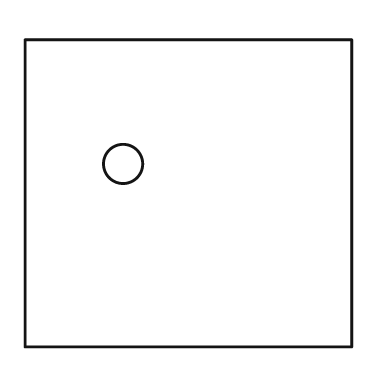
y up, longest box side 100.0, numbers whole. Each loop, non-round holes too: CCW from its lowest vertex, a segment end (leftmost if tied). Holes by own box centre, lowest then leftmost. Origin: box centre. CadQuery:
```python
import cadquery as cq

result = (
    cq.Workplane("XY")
    .moveTo(-50.0, -47.0)
    .lineTo(50.0, -47.0)
    .lineTo(50.0, 47.0)
    .lineTo(-50.0, 47.0)
    .close()
    .moveTo(-20.0, 9.0)
    .circle(6.0)
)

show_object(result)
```